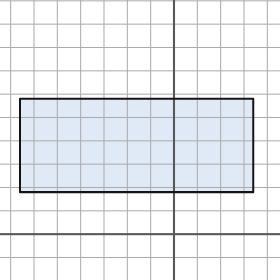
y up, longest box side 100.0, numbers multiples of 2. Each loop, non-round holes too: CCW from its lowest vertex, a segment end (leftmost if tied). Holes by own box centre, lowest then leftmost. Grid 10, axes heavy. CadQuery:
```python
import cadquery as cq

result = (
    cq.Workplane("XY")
    .moveTo(-66.0, 18.0)
    .lineTo(34.0, 18.0)
    .lineTo(34.0, 58.0)
    .lineTo(-66.0, 58.0)
    .close()
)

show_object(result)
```